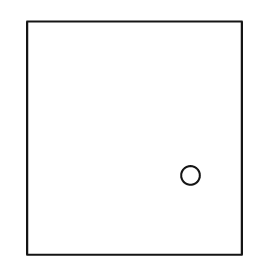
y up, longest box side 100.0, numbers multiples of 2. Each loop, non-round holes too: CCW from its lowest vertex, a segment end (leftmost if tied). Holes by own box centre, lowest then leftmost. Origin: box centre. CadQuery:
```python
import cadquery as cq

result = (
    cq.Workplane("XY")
    .moveTo(-46.0, -50.0)
    .lineTo(46.0, -50.0)
    .lineTo(46.0, 50.0)
    .lineTo(-46.0, 50.0)
    .close()
    .moveTo(24.0, -16.0)
    .circle(4.0)
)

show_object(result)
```